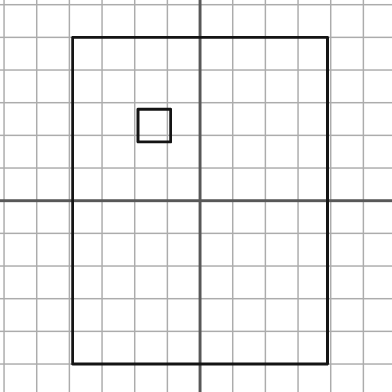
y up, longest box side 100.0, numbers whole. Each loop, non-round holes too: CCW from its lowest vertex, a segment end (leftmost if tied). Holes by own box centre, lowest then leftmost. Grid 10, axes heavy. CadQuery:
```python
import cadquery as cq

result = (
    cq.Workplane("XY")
    .moveTo(-39.0, -50.0)
    .lineTo(39.0, -50.0)
    .lineTo(39.0, 50.0)
    .lineTo(-39.0, 50.0)
    .close()
    .moveTo(-19.0, 18.0)
    .lineTo(-9.0, 18.0)
    .lineTo(-9.0, 28.0)
    .lineTo(-19.0, 28.0)
    .close()
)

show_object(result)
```